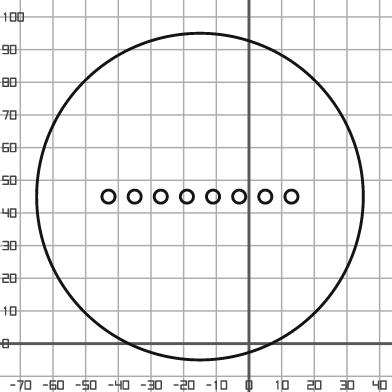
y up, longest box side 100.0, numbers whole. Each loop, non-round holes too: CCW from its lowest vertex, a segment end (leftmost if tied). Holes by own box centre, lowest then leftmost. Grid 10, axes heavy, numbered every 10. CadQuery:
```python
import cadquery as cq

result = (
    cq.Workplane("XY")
    .moveTo(-15.0, 45.0)
    .circle(50.0)
    .moveTo(-43.0, 45.0)
    .circle(2.0)
    .moveTo(-35.0, 45.0)
    .circle(2.0)
    .moveTo(-27.0, 45.0)
    .circle(2.0)
    .moveTo(-19.0, 45.0)
    .circle(2.0)
    .moveTo(-11.0, 45.0)
    .circle(2.0)
    .moveTo(-3.0, 45.0)
    .circle(2.0)
    .moveTo(5.0, 45.0)
    .circle(2.0)
    .moveTo(13.0, 45.0)
    .circle(2.0)
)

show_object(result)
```